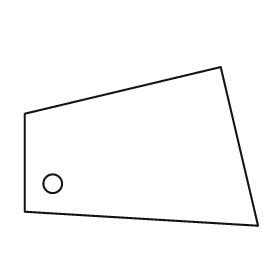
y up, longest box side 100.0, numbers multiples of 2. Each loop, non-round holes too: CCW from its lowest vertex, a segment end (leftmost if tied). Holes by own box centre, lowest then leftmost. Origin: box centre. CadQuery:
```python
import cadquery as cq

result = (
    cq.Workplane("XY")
    .moveTo(50.0, -34.0)
    .lineTo(34.0, 34.0)
    .lineTo(-50.0, 14.0)
    .lineTo(-50.0, -28.0)
    .close()
    .moveTo(-38.0, -16.0)
    .circle(4.0)
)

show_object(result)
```